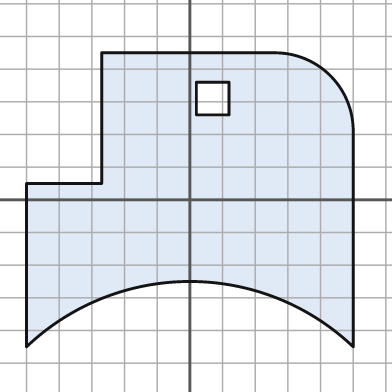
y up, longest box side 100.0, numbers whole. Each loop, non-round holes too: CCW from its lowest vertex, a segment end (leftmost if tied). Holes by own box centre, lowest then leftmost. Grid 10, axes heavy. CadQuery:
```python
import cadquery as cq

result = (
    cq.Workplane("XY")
    .moveTo(-50.0, -45.0)
    .threePointArc((0.0, -25.0), (50.0, -45.0))
    .lineTo(50.0, 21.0)
    .threePointArc((43.0, 38.0), (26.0, 45.0))
    .lineTo(-27.0, 45.0)
    .lineTo(-27.0, 5.0)
    .lineTo(-50.0, 5.0)
    .close()
    .moveTo(2.0, 26.0)
    .lineTo(12.0, 26.0)
    .lineTo(12.0, 36.0)
    .lineTo(2.0, 36.0)
    .close()
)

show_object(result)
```